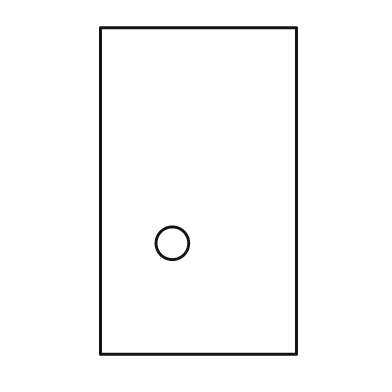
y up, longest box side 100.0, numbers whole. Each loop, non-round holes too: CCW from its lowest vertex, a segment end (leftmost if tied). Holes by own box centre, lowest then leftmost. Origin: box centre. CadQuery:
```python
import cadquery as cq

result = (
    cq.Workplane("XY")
    .moveTo(-30.0, -50.0)
    .lineTo(30.0, -50.0)
    .lineTo(30.0, 50.0)
    .lineTo(-30.0, 50.0)
    .close()
    .moveTo(-8.0, -16.0)
    .circle(5.0)
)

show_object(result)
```